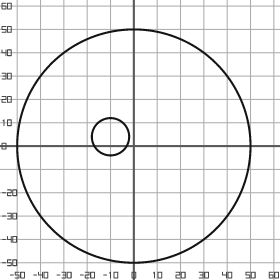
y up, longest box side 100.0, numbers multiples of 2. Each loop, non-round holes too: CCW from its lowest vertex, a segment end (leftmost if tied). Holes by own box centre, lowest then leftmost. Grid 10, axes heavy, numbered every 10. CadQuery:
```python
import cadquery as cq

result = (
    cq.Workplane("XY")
    .moveTo(0.0, 0.0)
    .circle(50.0)
    .moveTo(-10.0, 4.0)
    .circle(8.0)
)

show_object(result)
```